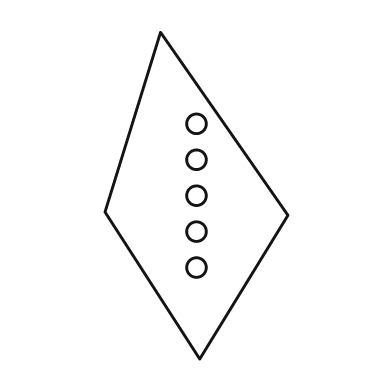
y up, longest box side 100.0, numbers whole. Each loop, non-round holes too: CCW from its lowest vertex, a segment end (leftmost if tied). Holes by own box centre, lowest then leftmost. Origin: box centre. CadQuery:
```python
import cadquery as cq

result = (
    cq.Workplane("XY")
    .moveTo(1.0, -50.0)
    .lineTo(28.0, -6.0)
    .lineTo(-11.0, 50.0)
    .lineTo(-28.0, -5.0)
    .close()
    .moveTo(0.0, -22.0)
    .circle(3.0)
    .moveTo(0.0, -11.0)
    .circle(3.0)
    .moveTo(0.0, 0.0)
    .circle(3.0)
    .moveTo(0.0, 11.0)
    .circle(3.0)
    .moveTo(0.0, 22.0)
    .circle(3.0)
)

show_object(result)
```